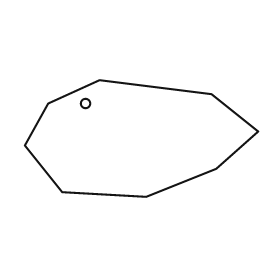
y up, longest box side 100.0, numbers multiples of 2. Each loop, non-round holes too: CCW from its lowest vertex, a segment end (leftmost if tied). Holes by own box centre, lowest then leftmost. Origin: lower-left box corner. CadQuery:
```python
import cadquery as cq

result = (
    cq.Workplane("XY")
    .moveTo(52.0, 0.0)
    .lineTo(82.0, 12.0)
    .lineTo(100.0, 28.0)
    .lineTo(80.0, 44.0)
    .lineTo(32.0, 50.0)
    .lineTo(10.0, 40.0)
    .lineTo(0.0, 22.0)
    .lineTo(16.0, 2.0)
    .close()
    .moveTo(26.0, 40.0)
    .circle(2.0)
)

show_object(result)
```